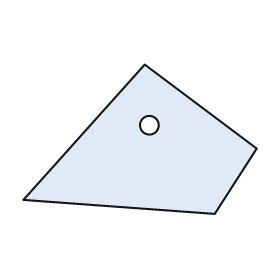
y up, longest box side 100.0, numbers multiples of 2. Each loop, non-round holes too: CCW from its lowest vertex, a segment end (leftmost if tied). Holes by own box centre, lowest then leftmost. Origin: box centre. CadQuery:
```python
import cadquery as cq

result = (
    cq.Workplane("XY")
    .moveTo(32.0, -32.0)
    .lineTo(50.0, -4.0)
    .lineTo(2.0, 32.0)
    .lineTo(-50.0, -26.0)
    .close()
    .moveTo(4.0, 6.0)
    .circle(4.0)
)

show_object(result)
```